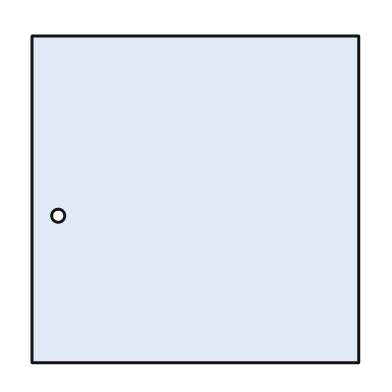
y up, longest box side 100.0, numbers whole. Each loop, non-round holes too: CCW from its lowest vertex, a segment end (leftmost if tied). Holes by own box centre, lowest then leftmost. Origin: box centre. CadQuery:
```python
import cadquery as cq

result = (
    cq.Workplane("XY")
    .moveTo(-50.0, -50.0)
    .lineTo(50.0, -50.0)
    .lineTo(50.0, 50.0)
    .lineTo(-50.0, 50.0)
    .close()
    .moveTo(-42.0, -5.0)
    .circle(2.0)
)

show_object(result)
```